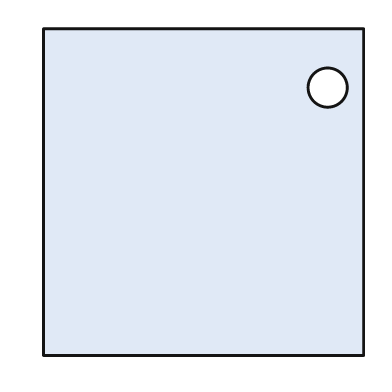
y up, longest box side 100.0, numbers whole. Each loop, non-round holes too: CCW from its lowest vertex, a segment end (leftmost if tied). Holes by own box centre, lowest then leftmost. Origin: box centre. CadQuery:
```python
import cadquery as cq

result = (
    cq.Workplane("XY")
    .moveTo(-49.0, -50.0)
    .lineTo(49.0, -50.0)
    .lineTo(49.0, 50.0)
    .lineTo(-49.0, 50.0)
    .close()
    .moveTo(38.0, 32.0)
    .circle(6.0)
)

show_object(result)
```